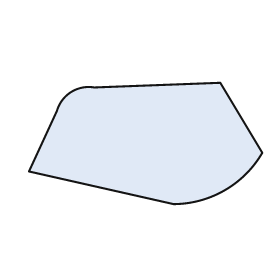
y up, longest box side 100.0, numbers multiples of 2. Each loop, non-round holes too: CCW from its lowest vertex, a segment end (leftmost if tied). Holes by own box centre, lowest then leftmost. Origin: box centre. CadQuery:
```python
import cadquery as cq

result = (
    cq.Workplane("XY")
    .moveTo(12.0, -26.0)
    .threePointArc((34.0, -20.0), (50.0, -4.0))
    .lineTo(32.0, 26.0)
    .lineTo(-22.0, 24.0)
    .threePointArc((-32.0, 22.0), (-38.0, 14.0))
    .lineTo(-50.0, -12.0)
    .close()
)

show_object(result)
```